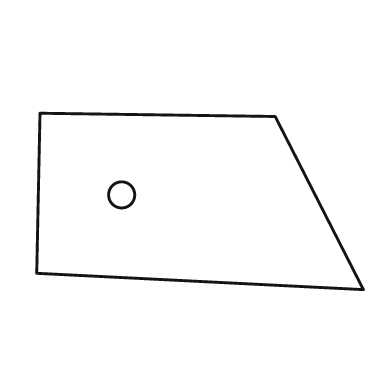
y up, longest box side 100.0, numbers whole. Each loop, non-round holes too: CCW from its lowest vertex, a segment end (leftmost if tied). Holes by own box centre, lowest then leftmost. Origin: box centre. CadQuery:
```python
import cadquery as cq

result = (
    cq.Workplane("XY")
    .moveTo(50.0, -27.0)
    .lineTo(23.0, 26.0)
    .lineTo(-49.0, 27.0)
    .lineTo(-50.0, -22.0)
    .close()
    .moveTo(-24.0, 2.0)
    .circle(4.0)
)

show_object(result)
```